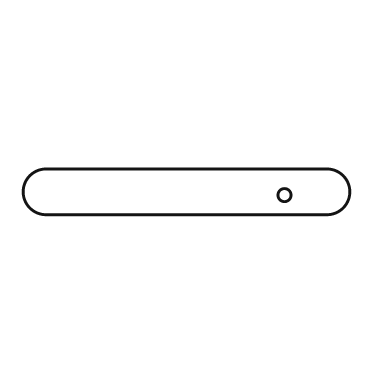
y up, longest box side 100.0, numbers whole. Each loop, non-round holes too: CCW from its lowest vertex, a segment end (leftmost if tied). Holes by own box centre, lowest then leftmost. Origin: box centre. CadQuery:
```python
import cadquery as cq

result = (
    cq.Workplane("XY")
    .moveTo(-43.0, -7.0)
    .lineTo(43.0, -7.0)
    .threePointArc((50.0, 0.0), (43.0, 7.0))
    .lineTo(-43.0, 7.0)
    .threePointArc((-50.0, 0.0), (-43.0, -7.0))
    .close()
    .moveTo(30.0, -1.0)
    .circle(2.0)
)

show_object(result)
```